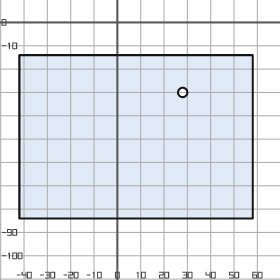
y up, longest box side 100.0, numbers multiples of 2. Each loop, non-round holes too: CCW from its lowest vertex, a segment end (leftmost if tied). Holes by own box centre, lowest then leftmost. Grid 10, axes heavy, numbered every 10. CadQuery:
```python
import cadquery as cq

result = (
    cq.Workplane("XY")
    .moveTo(-42.0, -84.0)
    .lineTo(58.0, -84.0)
    .lineTo(58.0, -14.0)
    .lineTo(-42.0, -14.0)
    .close()
    .moveTo(28.0, -30.0)
    .circle(2.0)
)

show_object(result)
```